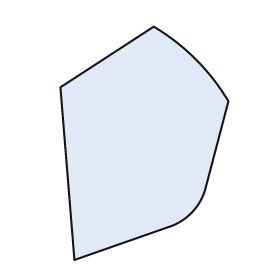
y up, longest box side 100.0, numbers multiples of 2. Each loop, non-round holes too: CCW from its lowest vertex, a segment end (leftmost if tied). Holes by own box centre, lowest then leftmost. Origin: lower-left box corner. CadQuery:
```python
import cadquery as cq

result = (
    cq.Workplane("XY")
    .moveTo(6.0, 0.0)
    .lineTo(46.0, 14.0)
    .threePointArc((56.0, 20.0), (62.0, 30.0))
    .lineTo(72.0, 68.0)
    .threePointArc((58.0, 86.0), (40.0, 100.0))
    .lineTo(0.0, 74.0)
    .close()
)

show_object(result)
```